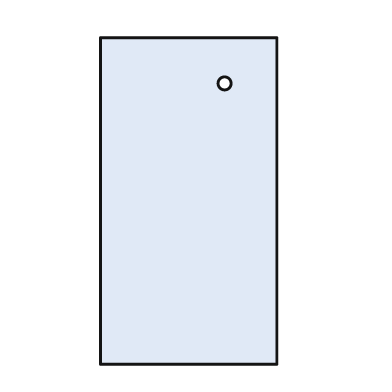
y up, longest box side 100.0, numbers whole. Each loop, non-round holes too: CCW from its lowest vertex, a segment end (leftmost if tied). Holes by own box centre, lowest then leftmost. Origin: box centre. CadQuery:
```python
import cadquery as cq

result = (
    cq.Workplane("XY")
    .moveTo(-27.0, -50.0)
    .lineTo(27.0, -50.0)
    .lineTo(27.0, 50.0)
    .lineTo(-27.0, 50.0)
    .close()
    .moveTo(11.0, 36.0)
    .circle(2.0)
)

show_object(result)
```